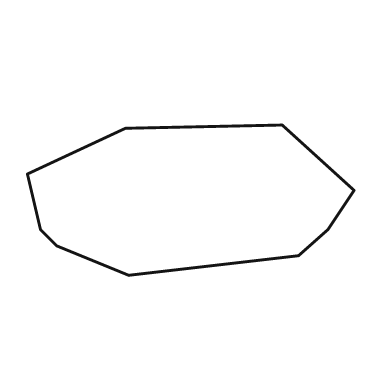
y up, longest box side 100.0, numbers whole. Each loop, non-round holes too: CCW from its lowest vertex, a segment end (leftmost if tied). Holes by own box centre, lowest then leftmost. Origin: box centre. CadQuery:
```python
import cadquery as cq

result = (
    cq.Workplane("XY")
    .moveTo(-19.0, -23.0)
    .lineTo(33.0, -17.0)
    .lineTo(42.0, -9.0)
    .lineTo(50.0, 3.0)
    .lineTo(28.0, 23.0)
    .lineTo(-20.0, 22.0)
    .lineTo(-50.0, 8.0)
    .lineTo(-46.0, -9.0)
    .lineTo(-41.0, -14.0)
    .close()
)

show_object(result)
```